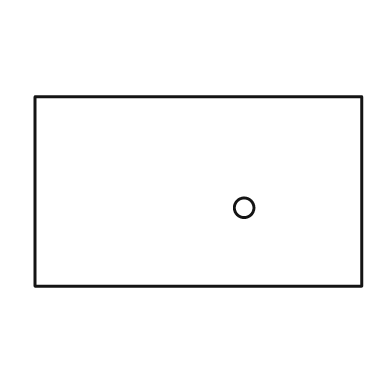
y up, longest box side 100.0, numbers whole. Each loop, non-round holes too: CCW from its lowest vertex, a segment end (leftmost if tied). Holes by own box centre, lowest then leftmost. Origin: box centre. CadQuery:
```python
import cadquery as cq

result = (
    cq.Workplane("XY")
    .moveTo(-50.0, -29.0)
    .lineTo(50.0, -29.0)
    .lineTo(50.0, 29.0)
    .lineTo(-50.0, 29.0)
    .close()
    .moveTo(14.0, -5.0)
    .circle(3.0)
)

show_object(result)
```